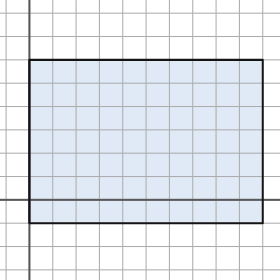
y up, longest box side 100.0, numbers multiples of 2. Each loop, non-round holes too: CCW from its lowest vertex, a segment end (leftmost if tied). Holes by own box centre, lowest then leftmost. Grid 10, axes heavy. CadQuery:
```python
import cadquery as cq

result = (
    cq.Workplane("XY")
    .moveTo(0.0, -10.0)
    .lineTo(100.0, -10.0)
    .lineTo(100.0, 60.0)
    .lineTo(0.0, 60.0)
    .close()
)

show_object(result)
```